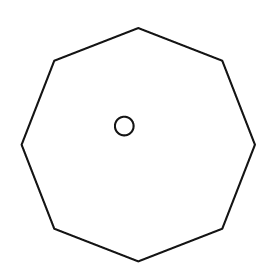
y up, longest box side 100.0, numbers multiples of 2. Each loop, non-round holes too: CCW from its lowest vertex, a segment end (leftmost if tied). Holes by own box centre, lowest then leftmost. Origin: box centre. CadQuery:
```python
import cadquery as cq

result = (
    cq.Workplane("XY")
    .moveTo(0.0, -50.0)
    .lineTo(36.0, -36.0)
    .lineTo(50.0, 0.0)
    .lineTo(36.0, 36.0)
    .lineTo(0.0, 50.0)
    .lineTo(-36.0, 36.0)
    .lineTo(-50.0, 0.0)
    .lineTo(-36.0, -36.0)
    .close()
    .moveTo(-6.0, 8.0)
    .circle(4.0)
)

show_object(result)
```